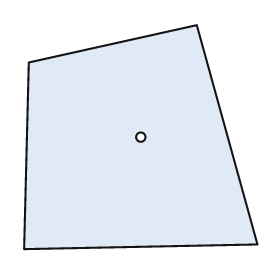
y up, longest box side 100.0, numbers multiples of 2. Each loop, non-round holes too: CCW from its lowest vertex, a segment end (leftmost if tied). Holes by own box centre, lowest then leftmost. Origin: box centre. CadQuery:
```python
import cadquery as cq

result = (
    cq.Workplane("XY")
    .moveTo(-50.0, -48.0)
    .lineTo(50.0, -46.0)
    .lineTo(24.0, 48.0)
    .lineTo(-48.0, 32.0)
    .close()
    .moveTo(0.0, 0.0)
    .circle(2.0)
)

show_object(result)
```